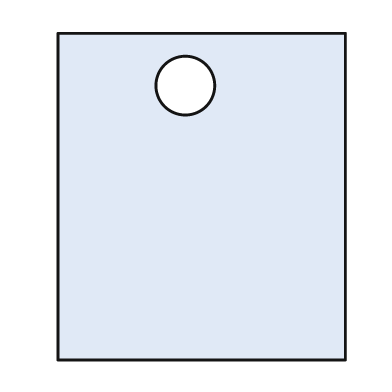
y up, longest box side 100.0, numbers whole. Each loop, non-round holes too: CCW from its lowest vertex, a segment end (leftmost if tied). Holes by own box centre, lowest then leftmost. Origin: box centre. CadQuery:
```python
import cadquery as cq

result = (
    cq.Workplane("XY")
    .moveTo(-44.0, -50.0)
    .lineTo(44.0, -50.0)
    .lineTo(44.0, 50.0)
    .lineTo(-44.0, 50.0)
    .close()
    .moveTo(-5.0, 34.0)
    .circle(9.0)
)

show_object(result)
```